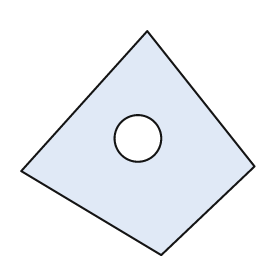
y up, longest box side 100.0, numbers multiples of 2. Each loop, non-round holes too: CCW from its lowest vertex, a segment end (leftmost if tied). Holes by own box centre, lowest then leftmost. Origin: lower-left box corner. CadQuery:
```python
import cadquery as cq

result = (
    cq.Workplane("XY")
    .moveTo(60.0, 0.0)
    .lineTo(100.0, 38.0)
    .lineTo(54.0, 96.0)
    .lineTo(0.0, 36.0)
    .close()
    .moveTo(50.0, 50.0)
    .circle(10.0)
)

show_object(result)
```